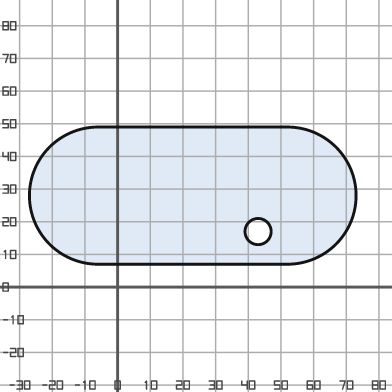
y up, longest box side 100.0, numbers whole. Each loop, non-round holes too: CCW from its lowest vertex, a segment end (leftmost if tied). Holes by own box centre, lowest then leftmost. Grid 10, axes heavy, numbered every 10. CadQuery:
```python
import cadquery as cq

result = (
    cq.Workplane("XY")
    .moveTo(-6.0, 7.0)
    .lineTo(52.0, 7.0)
    .threePointArc((73.0, 28.0), (52.0, 49.0))
    .lineTo(-6.0, 49.0)
    .threePointArc((-27.0, 28.0), (-6.0, 7.0))
    .close()
    .moveTo(43.0, 17.0)
    .circle(4.0)
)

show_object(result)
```